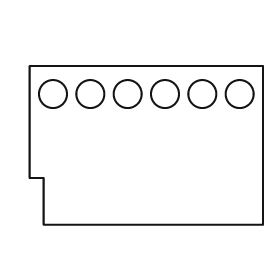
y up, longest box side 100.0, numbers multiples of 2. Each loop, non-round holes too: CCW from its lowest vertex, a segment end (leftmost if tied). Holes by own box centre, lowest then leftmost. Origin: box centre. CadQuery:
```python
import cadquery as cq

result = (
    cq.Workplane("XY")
    .moveTo(-44.0, -34.0)
    .lineTo(50.0, -34.0)
    .lineTo(50.0, 34.0)
    .lineTo(-50.0, 34.0)
    .lineTo(-50.0, -14.0)
    .lineTo(-44.0, -14.0)
    .close()
    .moveTo(-40.0, 22.0)
    .circle(6.0)
    .moveTo(-24.0, 22.0)
    .circle(6.0)
    .moveTo(-8.0, 22.0)
    .circle(6.0)
    .moveTo(8.0, 22.0)
    .circle(6.0)
    .moveTo(24.0, 22.0)
    .circle(6.0)
    .moveTo(40.0, 22.0)
    .circle(6.0)
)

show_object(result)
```